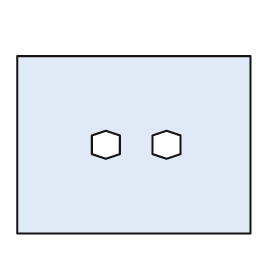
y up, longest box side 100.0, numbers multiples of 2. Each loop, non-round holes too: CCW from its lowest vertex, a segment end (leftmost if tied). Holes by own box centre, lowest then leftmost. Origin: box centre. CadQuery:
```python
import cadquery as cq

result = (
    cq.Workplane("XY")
    .moveTo(-50.0, -38.0)
    .lineTo(50.0, -38.0)
    .lineTo(50.0, 38.0)
    .lineTo(-50.0, 38.0)
    .close()
    .moveTo(-12.0, -6.0)
    .lineTo(-6.0, -4.0)
    .lineTo(-6.0, 4.0)
    .lineTo(-12.0, 6.0)
    .lineTo(-18.0, 4.0)
    .lineTo(-18.0, -4.0)
    .close()
    .moveTo(14.0, -6.0)
    .lineTo(20.0, -4.0)
    .lineTo(20.0, 4.0)
    .lineTo(14.0, 6.0)
    .lineTo(8.0, 4.0)
    .lineTo(8.0, -4.0)
    .close()
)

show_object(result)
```